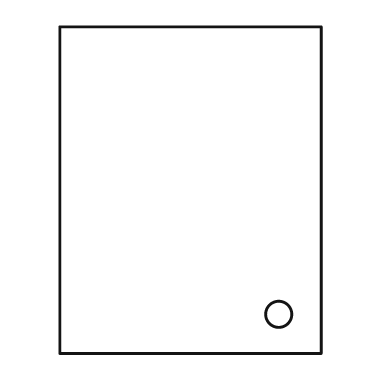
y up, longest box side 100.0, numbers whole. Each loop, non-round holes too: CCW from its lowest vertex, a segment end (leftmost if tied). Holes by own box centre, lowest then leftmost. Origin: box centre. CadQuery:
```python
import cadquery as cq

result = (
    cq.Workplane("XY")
    .moveTo(-40.0, -50.0)
    .lineTo(40.0, -50.0)
    .lineTo(40.0, 50.0)
    .lineTo(-40.0, 50.0)
    .close()
    .moveTo(27.0, -38.0)
    .circle(4.0)
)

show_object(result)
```